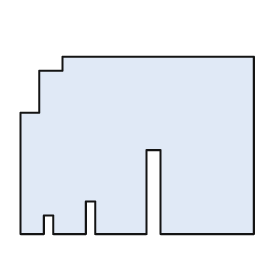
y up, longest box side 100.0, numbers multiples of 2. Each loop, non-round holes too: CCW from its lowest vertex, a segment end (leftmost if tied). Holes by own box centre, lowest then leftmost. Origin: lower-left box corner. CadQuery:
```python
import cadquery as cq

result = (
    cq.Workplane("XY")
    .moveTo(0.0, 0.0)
    .lineTo(10.0, 0.0)
    .lineTo(10.0, 8.0)
    .lineTo(14.0, 8.0)
    .lineTo(14.0, 0.0)
    .lineTo(28.0, 0.0)
    .lineTo(28.0, 14.0)
    .lineTo(32.0, 14.0)
    .lineTo(32.0, 0.0)
    .lineTo(54.0, 0.0)
    .lineTo(54.0, 36.0)
    .lineTo(60.0, 36.0)
    .lineTo(60.0, 0.0)
    .lineTo(100.0, 0.0)
    .lineTo(100.0, 76.0)
    .lineTo(18.0, 76.0)
    .lineTo(18.0, 70.0)
    .lineTo(8.0, 70.0)
    .lineTo(8.0, 52.0)
    .lineTo(0.0, 52.0)
    .close()
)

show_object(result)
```